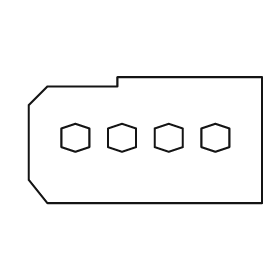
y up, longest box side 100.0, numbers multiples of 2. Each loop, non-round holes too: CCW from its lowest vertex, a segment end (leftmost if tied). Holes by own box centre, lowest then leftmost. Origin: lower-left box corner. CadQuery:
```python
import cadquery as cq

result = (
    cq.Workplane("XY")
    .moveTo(8.0, 0.0)
    .lineTo(100.0, 0.0)
    .lineTo(100.0, 54.0)
    .lineTo(38.0, 54.0)
    .lineTo(38.0, 50.0)
    .lineTo(8.0, 50.0)
    .lineTo(0.0, 42.0)
    .lineTo(0.0, 10.0)
    .close()
    .moveTo(20.0, 22.0)
    .lineTo(26.0, 24.0)
    .lineTo(26.0, 32.0)
    .lineTo(20.0, 34.0)
    .lineTo(14.0, 32.0)
    .lineTo(14.0, 24.0)
    .close()
    .moveTo(40.0, 22.0)
    .lineTo(46.0, 24.0)
    .lineTo(46.0, 32.0)
    .lineTo(40.0, 34.0)
    .lineTo(34.0, 32.0)
    .lineTo(34.0, 24.0)
    .close()
    .moveTo(60.0, 22.0)
    .lineTo(66.0, 24.0)
    .lineTo(66.0, 32.0)
    .lineTo(60.0, 34.0)
    .lineTo(54.0, 32.0)
    .lineTo(54.0, 24.0)
    .close()
    .moveTo(80.0, 22.0)
    .lineTo(86.0, 24.0)
    .lineTo(86.0, 32.0)
    .lineTo(80.0, 34.0)
    .lineTo(74.0, 32.0)
    .lineTo(74.0, 24.0)
    .close()
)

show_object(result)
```